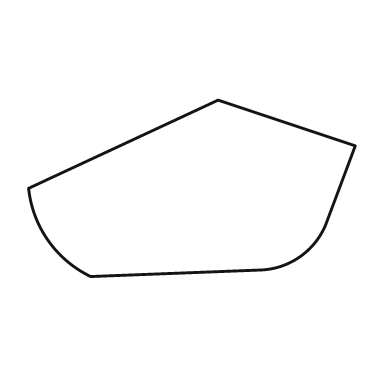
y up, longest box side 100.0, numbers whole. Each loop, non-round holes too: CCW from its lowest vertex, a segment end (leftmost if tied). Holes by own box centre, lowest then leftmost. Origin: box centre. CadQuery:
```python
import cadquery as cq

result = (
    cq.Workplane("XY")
    .moveTo(-31.0, -27.0)
    .lineTo(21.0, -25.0)
    .threePointArc((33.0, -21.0), (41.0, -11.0))
    .lineTo(50.0, 13.0)
    .lineTo(8.0, 27.0)
    .lineTo(-50.0, 0.0)
    .threePointArc((-44.0, -16.0), (-31.0, -27.0))
    .close()
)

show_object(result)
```